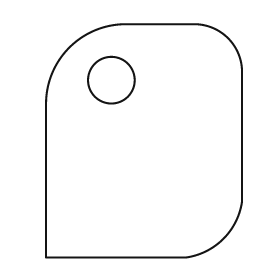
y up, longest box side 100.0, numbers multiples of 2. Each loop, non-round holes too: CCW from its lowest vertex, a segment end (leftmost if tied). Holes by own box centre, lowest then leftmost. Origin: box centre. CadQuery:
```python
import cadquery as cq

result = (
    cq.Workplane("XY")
    .moveTo(-42.0, -50.0)
    .lineTo(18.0, -50.0)
    .threePointArc((34.0, -42.0), (42.0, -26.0))
    .lineTo(42.0, 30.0)
    .threePointArc((36.0, 44.0), (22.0, 50.0))
    .lineTo(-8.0, 50.0)
    .threePointArc((-32.0, 40.0), (-42.0, 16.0))
    .close()
    .moveTo(-14.0, 26.0)
    .circle(10.0)
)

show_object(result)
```